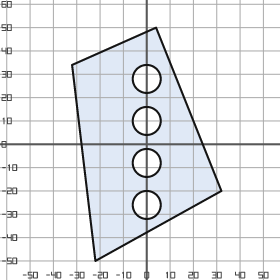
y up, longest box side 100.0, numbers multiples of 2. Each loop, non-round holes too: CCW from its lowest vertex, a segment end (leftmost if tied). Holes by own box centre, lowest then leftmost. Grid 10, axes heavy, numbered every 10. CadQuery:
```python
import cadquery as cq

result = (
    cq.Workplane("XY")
    .moveTo(-22.0, -50.0)
    .lineTo(32.0, -20.0)
    .lineTo(4.0, 50.0)
    .lineTo(-32.0, 34.0)
    .close()
    .moveTo(0.0, -26.0)
    .circle(6.0)
    .moveTo(0.0, -8.0)
    .circle(6.0)
    .moveTo(0.0, 10.0)
    .circle(6.0)
    .moveTo(0.0, 28.0)
    .circle(6.0)
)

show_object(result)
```